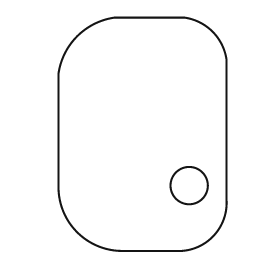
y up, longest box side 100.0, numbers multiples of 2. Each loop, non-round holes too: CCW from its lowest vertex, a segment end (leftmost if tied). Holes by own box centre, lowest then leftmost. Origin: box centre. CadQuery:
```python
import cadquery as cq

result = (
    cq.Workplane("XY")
    .moveTo(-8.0, -50.0)
    .lineTo(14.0, -50.0)
    .threePointArc((30.0, -44.0), (36.0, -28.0))
    .lineTo(36.0, 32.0)
    .threePointArc((30.0, 44.0), (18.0, 50.0))
    .lineTo(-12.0, 50.0)
    .threePointArc((-28.0, 42.0), (-36.0, 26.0))
    .lineTo(-36.0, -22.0)
    .threePointArc((-28.0, -42.0), (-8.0, -50.0))
    .close()
    .moveTo(20.0, -22.0)
    .circle(8.0)
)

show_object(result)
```